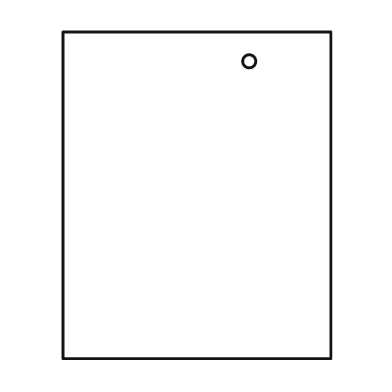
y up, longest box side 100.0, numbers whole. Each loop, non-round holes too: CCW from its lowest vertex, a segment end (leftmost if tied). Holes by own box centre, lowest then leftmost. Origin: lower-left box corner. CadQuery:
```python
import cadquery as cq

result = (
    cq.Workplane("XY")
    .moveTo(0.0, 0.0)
    .lineTo(82.0, 0.0)
    .lineTo(82.0, 100.0)
    .lineTo(0.0, 100.0)
    .close()
    .moveTo(57.0, 91.0)
    .circle(2.0)
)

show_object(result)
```